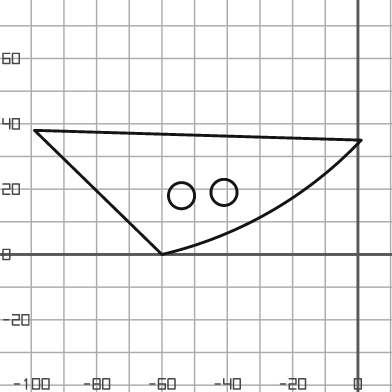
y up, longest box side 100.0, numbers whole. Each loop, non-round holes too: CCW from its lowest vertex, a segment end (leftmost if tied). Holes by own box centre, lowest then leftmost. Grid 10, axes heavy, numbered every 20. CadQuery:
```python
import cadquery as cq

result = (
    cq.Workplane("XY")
    .moveTo(-60.0, 0.0)
    .threePointArc((-27.0, 13.0), (1.0, 35.0))
    .lineTo(-99.0, 38.0)
    .close()
    .moveTo(-54.0, 18.0)
    .circle(4.0)
    .moveTo(-41.0, 19.0)
    .circle(4.0)
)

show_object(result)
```